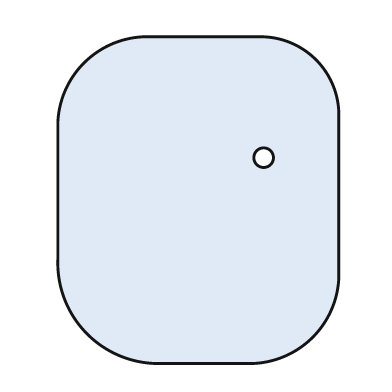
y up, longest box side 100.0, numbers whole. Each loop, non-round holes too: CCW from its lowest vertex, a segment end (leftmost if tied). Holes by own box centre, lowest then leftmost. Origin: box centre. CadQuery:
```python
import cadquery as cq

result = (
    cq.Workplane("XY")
    .moveTo(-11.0, -50.0)
    .lineTo(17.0, -50.0)
    .threePointArc((35.0, -42.0), (43.0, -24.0))
    .lineTo(43.0, 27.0)
    .threePointArc((36.0, 43.0), (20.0, 50.0))
    .lineTo(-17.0, 50.0)
    .threePointArc((-35.0, 42.0), (-43.0, 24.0))
    .lineTo(-43.0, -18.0)
    .threePointArc((-34.0, -41.0), (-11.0, -50.0))
    .close()
    .moveTo(20.0, 13.0)
    .circle(3.0)
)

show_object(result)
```